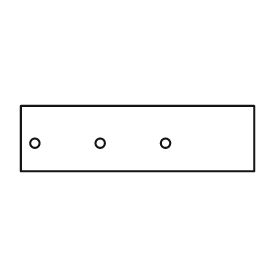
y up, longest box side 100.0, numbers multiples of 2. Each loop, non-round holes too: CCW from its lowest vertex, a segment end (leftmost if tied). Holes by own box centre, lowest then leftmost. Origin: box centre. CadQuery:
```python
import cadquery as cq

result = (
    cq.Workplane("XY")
    .moveTo(-50.0, -14.0)
    .lineTo(50.0, -14.0)
    .lineTo(50.0, 14.0)
    .lineTo(-50.0, 14.0)
    .close()
    .moveTo(-44.0, -2.0)
    .circle(2.0)
    .moveTo(-16.0, -2.0)
    .circle(2.0)
    .moveTo(12.0, -2.0)
    .circle(2.0)
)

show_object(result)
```